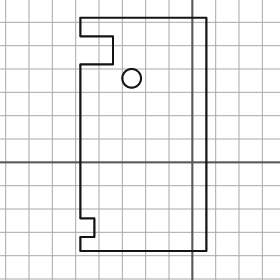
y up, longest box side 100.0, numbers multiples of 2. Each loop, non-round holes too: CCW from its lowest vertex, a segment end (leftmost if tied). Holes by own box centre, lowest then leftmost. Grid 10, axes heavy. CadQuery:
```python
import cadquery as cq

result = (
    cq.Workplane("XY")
    .moveTo(-48.0, -38.0)
    .lineTo(6.0, -38.0)
    .lineTo(6.0, 62.0)
    .lineTo(-48.0, 62.0)
    .lineTo(-48.0, 54.0)
    .lineTo(-34.0, 54.0)
    .lineTo(-34.0, 42.0)
    .lineTo(-48.0, 42.0)
    .lineTo(-48.0, -24.0)
    .lineTo(-42.0, -24.0)
    .lineTo(-42.0, -32.0)
    .lineTo(-48.0, -32.0)
    .close()
    .moveTo(-26.0, 36.0)
    .circle(4.0)
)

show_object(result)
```